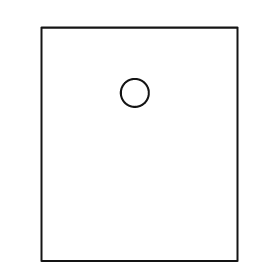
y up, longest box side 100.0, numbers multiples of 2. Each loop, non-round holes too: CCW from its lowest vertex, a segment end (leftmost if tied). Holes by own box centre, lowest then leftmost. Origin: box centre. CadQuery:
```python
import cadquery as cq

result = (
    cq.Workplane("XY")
    .moveTo(-42.0, -50.0)
    .lineTo(42.0, -50.0)
    .lineTo(42.0, 50.0)
    .lineTo(-42.0, 50.0)
    .close()
    .moveTo(-2.0, 22.0)
    .circle(6.0)
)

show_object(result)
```